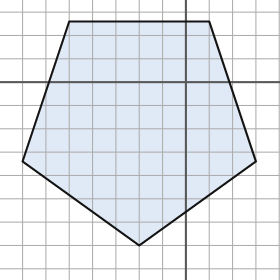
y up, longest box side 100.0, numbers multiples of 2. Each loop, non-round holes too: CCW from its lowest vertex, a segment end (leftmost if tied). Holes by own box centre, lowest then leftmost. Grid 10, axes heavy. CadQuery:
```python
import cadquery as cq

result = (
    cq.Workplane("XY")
    .moveTo(-20.0, -70.0)
    .lineTo(30.0, -34.0)
    .lineTo(10.0, 26.0)
    .lineTo(-50.0, 26.0)
    .lineTo(-70.0, -34.0)
    .close()
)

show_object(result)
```